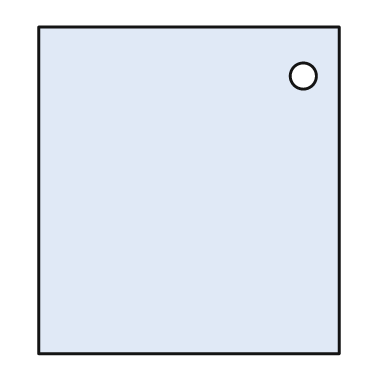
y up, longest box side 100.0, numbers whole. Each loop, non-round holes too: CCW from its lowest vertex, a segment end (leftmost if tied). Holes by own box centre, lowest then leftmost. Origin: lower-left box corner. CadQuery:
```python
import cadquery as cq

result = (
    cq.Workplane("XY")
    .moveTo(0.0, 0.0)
    .lineTo(92.0, 0.0)
    .lineTo(92.0, 100.0)
    .lineTo(0.0, 100.0)
    .close()
    .moveTo(81.0, 85.0)
    .circle(4.0)
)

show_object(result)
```